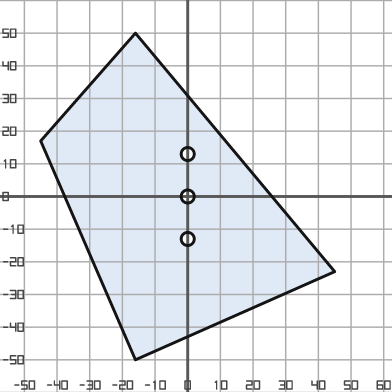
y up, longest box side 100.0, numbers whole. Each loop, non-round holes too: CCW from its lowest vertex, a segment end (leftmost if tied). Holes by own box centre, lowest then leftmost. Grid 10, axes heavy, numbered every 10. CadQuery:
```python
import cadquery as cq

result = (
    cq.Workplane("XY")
    .moveTo(-16.0, -50.0)
    .lineTo(45.0, -23.0)
    .lineTo(-16.0, 50.0)
    .lineTo(-45.0, 17.0)
    .close()
    .moveTo(0.0, -13.0)
    .circle(2.0)
    .moveTo(0.0, 0.0)
    .circle(2.0)
    .moveTo(0.0, 13.0)
    .circle(2.0)
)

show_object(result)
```